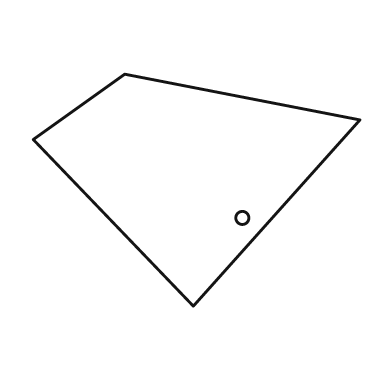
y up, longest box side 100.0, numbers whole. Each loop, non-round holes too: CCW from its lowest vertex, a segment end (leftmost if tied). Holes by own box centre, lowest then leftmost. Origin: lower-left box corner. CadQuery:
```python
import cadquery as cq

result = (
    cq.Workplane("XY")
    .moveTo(49.0, 0.0)
    .lineTo(100.0, 57.0)
    .lineTo(28.0, 71.0)
    .lineTo(0.0, 51.0)
    .close()
    .moveTo(64.0, 27.0)
    .circle(2.0)
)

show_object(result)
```